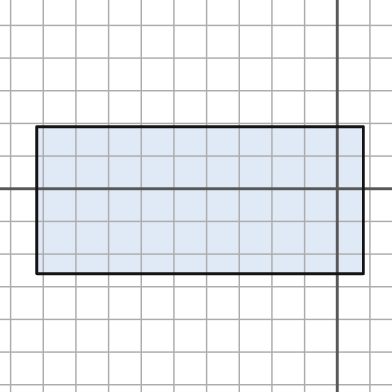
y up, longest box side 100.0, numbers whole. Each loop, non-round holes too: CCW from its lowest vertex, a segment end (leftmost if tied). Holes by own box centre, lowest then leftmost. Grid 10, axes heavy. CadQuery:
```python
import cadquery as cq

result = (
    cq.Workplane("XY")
    .moveTo(-92.0, -26.0)
    .lineTo(8.0, -26.0)
    .lineTo(8.0, 19.0)
    .lineTo(-92.0, 19.0)
    .close()
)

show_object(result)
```